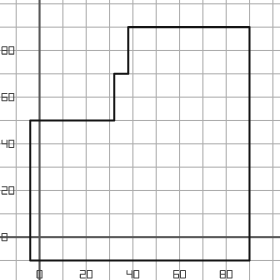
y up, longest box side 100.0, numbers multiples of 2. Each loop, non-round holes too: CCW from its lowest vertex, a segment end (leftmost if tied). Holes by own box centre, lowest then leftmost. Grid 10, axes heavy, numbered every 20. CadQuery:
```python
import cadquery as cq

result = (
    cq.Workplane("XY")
    .moveTo(-4.0, -10.0)
    .lineTo(90.0, -10.0)
    .lineTo(90.0, 90.0)
    .lineTo(38.0, 90.0)
    .lineTo(38.0, 70.0)
    .lineTo(32.0, 70.0)
    .lineTo(32.0, 50.0)
    .lineTo(-4.0, 50.0)
    .close()
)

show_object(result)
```